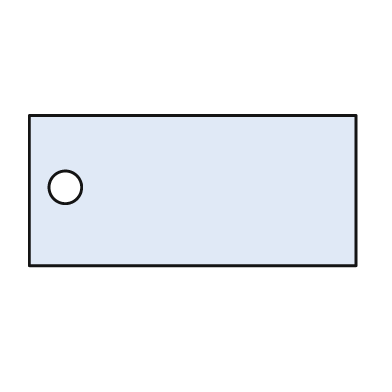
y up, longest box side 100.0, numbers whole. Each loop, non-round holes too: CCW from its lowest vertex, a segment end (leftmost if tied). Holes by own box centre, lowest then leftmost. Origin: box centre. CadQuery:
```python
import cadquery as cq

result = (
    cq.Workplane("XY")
    .moveTo(-50.0, -23.0)
    .lineTo(50.0, -23.0)
    .lineTo(50.0, 23.0)
    .lineTo(-50.0, 23.0)
    .close()
    .moveTo(-39.0, 1.0)
    .circle(5.0)
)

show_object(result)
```